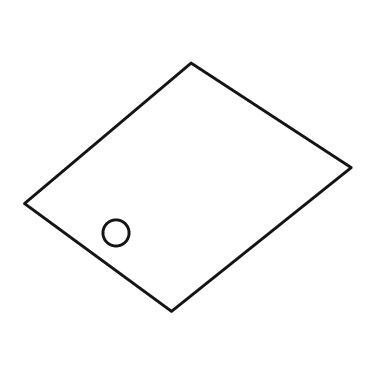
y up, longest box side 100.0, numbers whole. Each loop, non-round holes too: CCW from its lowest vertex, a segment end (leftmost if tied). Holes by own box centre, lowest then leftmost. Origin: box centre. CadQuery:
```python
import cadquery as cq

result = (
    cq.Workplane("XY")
    .moveTo(-5.0, -38.0)
    .lineTo(50.0, 6.0)
    .lineTo(1.0, 38.0)
    .lineTo(-50.0, -5.0)
    .close()
    .moveTo(-22.0, -14.0)
    .circle(4.0)
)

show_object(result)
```